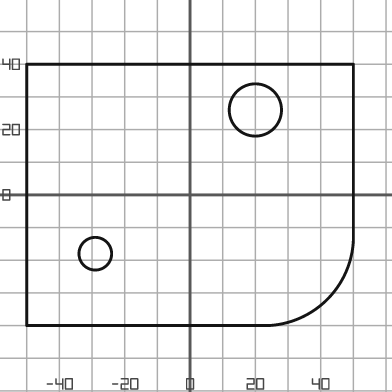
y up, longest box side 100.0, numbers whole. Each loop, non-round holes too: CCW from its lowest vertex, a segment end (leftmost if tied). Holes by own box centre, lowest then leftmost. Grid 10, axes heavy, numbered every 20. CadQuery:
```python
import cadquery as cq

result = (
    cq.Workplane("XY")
    .moveTo(-50.0, -40.0)
    .lineTo(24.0, -40.0)
    .threePointArc((42.0, -32.0), (50.0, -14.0))
    .lineTo(50.0, 40.0)
    .lineTo(-50.0, 40.0)
    .close()
    .moveTo(-29.0, -18.0)
    .circle(5.0)
    .moveTo(20.0, 26.0)
    .circle(8.0)
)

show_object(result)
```